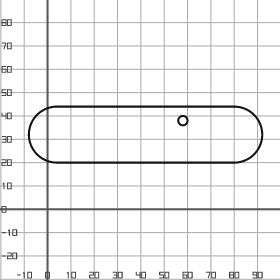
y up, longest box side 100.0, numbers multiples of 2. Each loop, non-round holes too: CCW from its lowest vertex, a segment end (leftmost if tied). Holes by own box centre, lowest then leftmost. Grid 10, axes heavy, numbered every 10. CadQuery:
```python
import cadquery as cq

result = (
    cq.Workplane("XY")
    .moveTo(4.0, 20.0)
    .lineTo(80.0, 20.0)
    .threePointArc((92.0, 32.0), (80.0, 44.0))
    .lineTo(4.0, 44.0)
    .threePointArc((-8.0, 32.0), (4.0, 20.0))
    .close()
    .moveTo(58.0, 38.0)
    .circle(2.0)
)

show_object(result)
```